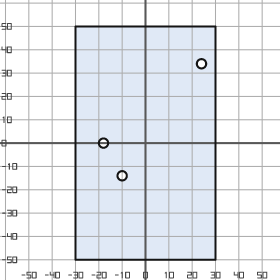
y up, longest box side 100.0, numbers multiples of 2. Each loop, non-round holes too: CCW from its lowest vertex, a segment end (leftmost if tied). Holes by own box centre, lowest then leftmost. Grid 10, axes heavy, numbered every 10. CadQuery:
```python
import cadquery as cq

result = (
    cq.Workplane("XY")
    .moveTo(-30.0, -50.0)
    .lineTo(30.0, -50.0)
    .lineTo(30.0, 50.0)
    .lineTo(-30.0, 50.0)
    .close()
    .moveTo(-10.0, -14.0)
    .circle(2.0)
    .moveTo(-18.0, 0.0)
    .circle(2.0)
    .moveTo(24.0, 34.0)
    .circle(2.0)
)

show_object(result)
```